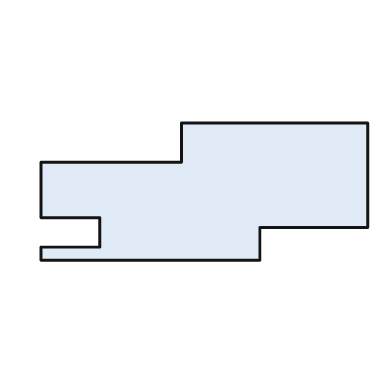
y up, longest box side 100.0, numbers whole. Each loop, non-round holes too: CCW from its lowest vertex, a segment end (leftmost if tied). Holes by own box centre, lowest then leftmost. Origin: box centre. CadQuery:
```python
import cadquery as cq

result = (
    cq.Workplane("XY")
    .moveTo(-50.0, -21.0)
    .lineTo(17.0, -21.0)
    .lineTo(17.0, -11.0)
    .lineTo(50.0, -11.0)
    .lineTo(50.0, 21.0)
    .lineTo(-7.0, 21.0)
    .lineTo(-7.0, 9.0)
    .lineTo(-50.0, 9.0)
    .lineTo(-50.0, -8.0)
    .lineTo(-32.0, -8.0)
    .lineTo(-32.0, -17.0)
    .lineTo(-50.0, -17.0)
    .close()
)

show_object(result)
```